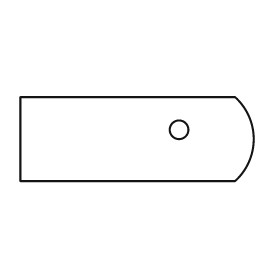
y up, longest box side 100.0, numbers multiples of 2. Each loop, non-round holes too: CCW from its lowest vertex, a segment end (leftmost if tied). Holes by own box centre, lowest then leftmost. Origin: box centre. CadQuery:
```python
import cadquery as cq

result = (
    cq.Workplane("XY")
    .moveTo(-50.0, -18.0)
    .lineTo(42.0, -18.0)
    .threePointArc((50.0, 0.0), (42.0, 18.0))
    .lineTo(-50.0, 18.0)
    .close()
    .moveTo(18.0, 4.0)
    .circle(4.0)
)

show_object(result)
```